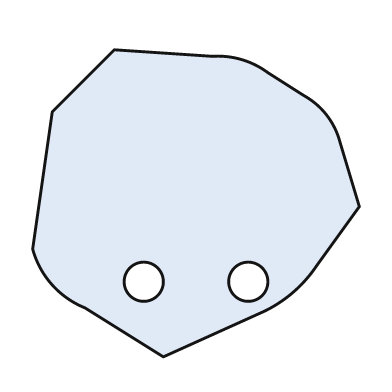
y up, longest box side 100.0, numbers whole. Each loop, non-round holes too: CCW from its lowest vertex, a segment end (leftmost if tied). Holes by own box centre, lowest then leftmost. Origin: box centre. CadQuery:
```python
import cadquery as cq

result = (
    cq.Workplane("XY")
    .moveTo(-10.0, -47.0)
    .lineTo(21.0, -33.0)
    .threePointArc((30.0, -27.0), (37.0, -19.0))
    .lineTo(50.0, -1.0)
    .lineTo(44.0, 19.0)
    .threePointArc((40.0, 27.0), (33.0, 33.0))
    .lineTo(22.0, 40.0)
    .threePointArc((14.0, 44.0), (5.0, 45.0))
    .lineTo(-25.0, 47.0)
    .lineTo(-44.0, 28.0)
    .lineTo(-50.0, -14.0)
    .threePointArc((-44.0, -25.0), (-34.0, -32.0))
    .close()
    .moveTo(-16.0, -24.0)
    .circle(6.0)
    .moveTo(16.0, -24.0)
    .circle(6.0)
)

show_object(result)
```